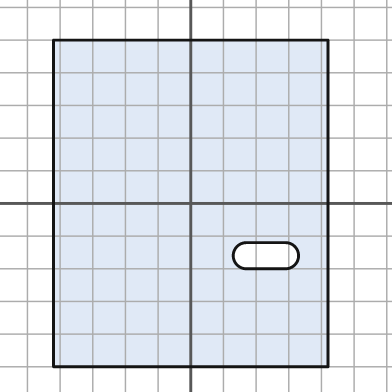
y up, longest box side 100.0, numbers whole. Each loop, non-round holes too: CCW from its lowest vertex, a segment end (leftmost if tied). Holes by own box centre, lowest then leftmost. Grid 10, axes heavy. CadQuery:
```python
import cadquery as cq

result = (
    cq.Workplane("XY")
    .moveTo(-42.0, -50.0)
    .lineTo(42.0, -50.0)
    .lineTo(42.0, 50.0)
    .lineTo(-42.0, 50.0)
    .close()
    .moveTo(17.0, -20.0)
    .lineTo(29.0, -20.0)
    .threePointArc((33.0, -16.0), (29.0, -12.0))
    .lineTo(17.0, -12.0)
    .threePointArc((13.0, -16.0), (17.0, -20.0))
    .close()
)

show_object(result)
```